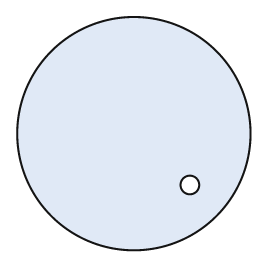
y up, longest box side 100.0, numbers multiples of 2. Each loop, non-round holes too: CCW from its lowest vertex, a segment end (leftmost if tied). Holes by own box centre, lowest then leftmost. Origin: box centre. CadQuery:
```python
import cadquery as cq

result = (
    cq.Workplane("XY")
    .moveTo(0.0, 0.0)
    .circle(50.0)
    .moveTo(24.0, -22.0)
    .circle(4.0)
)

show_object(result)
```